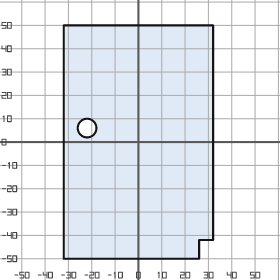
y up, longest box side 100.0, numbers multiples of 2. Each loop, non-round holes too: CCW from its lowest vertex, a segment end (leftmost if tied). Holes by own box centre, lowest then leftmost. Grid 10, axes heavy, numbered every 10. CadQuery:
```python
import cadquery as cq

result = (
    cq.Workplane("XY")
    .moveTo(-32.0, -50.0)
    .lineTo(26.0, -50.0)
    .lineTo(26.0, -42.0)
    .lineTo(32.0, -42.0)
    .lineTo(32.0, 50.0)
    .lineTo(-32.0, 50.0)
    .close()
    .moveTo(-22.0, 6.0)
    .circle(4.0)
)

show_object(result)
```